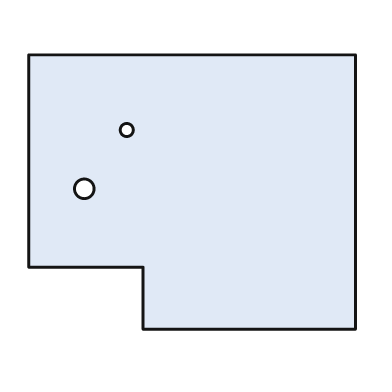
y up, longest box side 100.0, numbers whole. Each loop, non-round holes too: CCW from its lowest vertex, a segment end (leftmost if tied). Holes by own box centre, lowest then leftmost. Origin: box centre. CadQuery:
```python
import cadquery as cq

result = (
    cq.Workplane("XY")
    .moveTo(-15.0, -42.0)
    .lineTo(50.0, -42.0)
    .lineTo(50.0, 42.0)
    .lineTo(-50.0, 42.0)
    .lineTo(-50.0, -23.0)
    .lineTo(-15.0, -23.0)
    .close()
    .moveTo(-33.0, 1.0)
    .circle(3.0)
    .moveTo(-20.0, 19.0)
    .circle(2.0)
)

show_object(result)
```